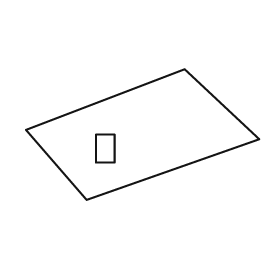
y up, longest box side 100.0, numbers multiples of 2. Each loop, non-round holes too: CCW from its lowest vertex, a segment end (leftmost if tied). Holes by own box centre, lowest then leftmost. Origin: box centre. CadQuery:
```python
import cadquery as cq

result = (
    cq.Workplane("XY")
    .moveTo(-24.0, -28.0)
    .lineTo(50.0, -2.0)
    .lineTo(18.0, 28.0)
    .lineTo(-50.0, 2.0)
    .close()
    .moveTo(-20.0, -12.0)
    .lineTo(-12.0, -12.0)
    .lineTo(-12.0, 0.0)
    .lineTo(-20.0, 0.0)
    .close()
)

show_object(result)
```